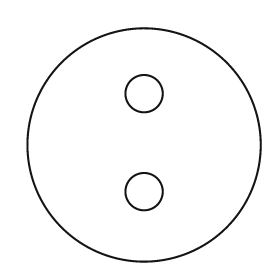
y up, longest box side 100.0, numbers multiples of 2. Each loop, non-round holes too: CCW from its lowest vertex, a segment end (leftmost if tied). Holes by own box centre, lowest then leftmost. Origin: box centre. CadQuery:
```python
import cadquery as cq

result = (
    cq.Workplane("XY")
    .moveTo(0.0, 0.0)
    .circle(50.0)
    .moveTo(0.0, -20.0)
    .circle(8.0)
    .moveTo(0.0, 22.0)
    .circle(8.0)
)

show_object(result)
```